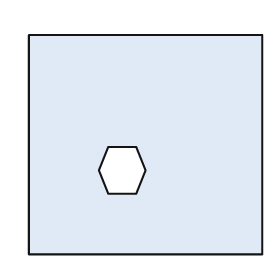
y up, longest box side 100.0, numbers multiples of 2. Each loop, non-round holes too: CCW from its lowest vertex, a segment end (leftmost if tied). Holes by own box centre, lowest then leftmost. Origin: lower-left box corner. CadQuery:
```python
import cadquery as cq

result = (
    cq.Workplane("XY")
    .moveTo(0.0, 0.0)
    .lineTo(100.0, 0.0)
    .lineTo(100.0, 94.0)
    .lineTo(0.0, 94.0)
    .close()
    .moveTo(34.0, 26.0)
    .lineTo(46.0, 26.0)
    .lineTo(50.0, 36.0)
    .lineTo(46.0, 46.0)
    .lineTo(34.0, 46.0)
    .lineTo(30.0, 36.0)
    .close()
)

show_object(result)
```